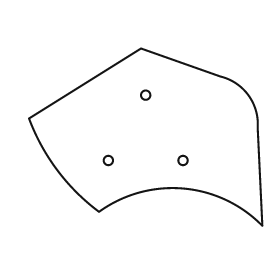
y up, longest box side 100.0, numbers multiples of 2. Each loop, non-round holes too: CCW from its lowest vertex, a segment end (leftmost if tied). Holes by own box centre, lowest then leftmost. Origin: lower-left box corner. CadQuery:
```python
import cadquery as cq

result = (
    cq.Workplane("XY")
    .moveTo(100.0, 0.0)
    .lineTo(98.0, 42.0)
    .threePointArc((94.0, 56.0), (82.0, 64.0))
    .lineTo(48.0, 76.0)
    .lineTo(0.0, 46.0)
    .threePointArc((12.0, 24.0), (30.0, 6.0))
    .threePointArc((66.0, 16.0), (100.0, 0.0))
    .close()
    .moveTo(34.0, 28.0)
    .circle(2.0)
    .moveTo(66.0, 28.0)
    .circle(2.0)
    .moveTo(50.0, 56.0)
    .circle(2.0)
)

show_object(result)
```